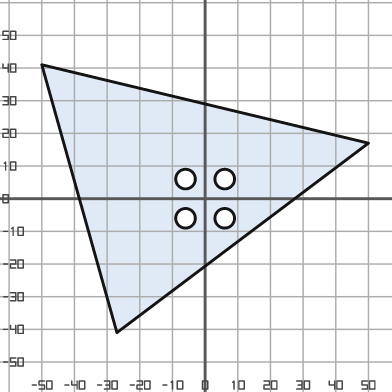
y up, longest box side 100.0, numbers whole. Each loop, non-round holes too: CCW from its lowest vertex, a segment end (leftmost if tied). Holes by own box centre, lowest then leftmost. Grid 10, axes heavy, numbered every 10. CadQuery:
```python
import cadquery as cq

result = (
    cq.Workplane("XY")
    .moveTo(-27.0, -41.0)
    .lineTo(50.0, 17.0)
    .lineTo(-50.0, 41.0)
    .close()
    .moveTo(-6.0, -6.0)
    .circle(3.0)
    .moveTo(6.0, -6.0)
    .circle(3.0)
    .moveTo(-6.0, 6.0)
    .circle(3.0)
    .moveTo(6.0, 6.0)
    .circle(3.0)
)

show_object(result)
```